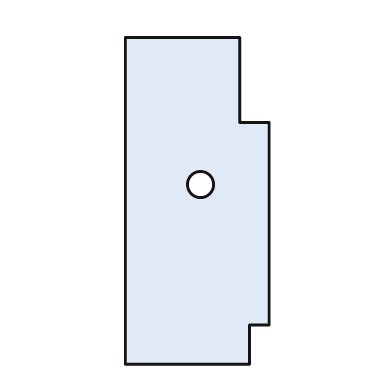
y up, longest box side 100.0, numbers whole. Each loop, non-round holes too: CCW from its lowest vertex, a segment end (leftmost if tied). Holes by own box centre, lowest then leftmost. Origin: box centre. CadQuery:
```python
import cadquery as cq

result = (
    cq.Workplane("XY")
    .moveTo(-22.0, -50.0)
    .lineTo(16.0, -50.0)
    .lineTo(16.0, -38.0)
    .lineTo(22.0, -38.0)
    .lineTo(22.0, 24.0)
    .lineTo(13.0, 24.0)
    .lineTo(13.0, 50.0)
    .lineTo(-22.0, 50.0)
    .close()
    .moveTo(1.0, 5.0)
    .circle(4.0)
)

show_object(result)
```